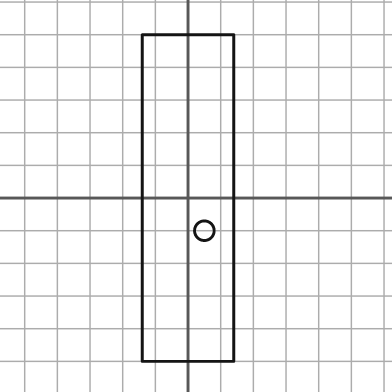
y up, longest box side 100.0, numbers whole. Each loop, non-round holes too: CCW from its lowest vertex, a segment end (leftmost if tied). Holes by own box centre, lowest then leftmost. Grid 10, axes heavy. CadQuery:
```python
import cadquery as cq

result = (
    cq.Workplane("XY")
    .moveTo(-14.0, -50.0)
    .lineTo(14.0, -50.0)
    .lineTo(14.0, 50.0)
    .lineTo(-14.0, 50.0)
    .close()
    .moveTo(5.0, -10.0)
    .circle(3.0)
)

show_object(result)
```